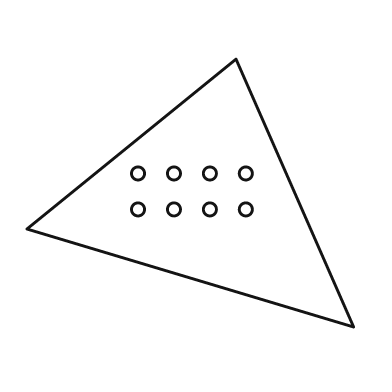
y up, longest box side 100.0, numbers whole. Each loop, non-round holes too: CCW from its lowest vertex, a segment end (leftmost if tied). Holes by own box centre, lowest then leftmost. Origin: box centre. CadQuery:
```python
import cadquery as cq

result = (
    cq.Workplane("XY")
    .moveTo(50.0, -41.0)
    .lineTo(14.0, 41.0)
    .lineTo(-50.0, -11.0)
    .close()
    .moveTo(-16.0, -5.0)
    .circle(2.0)
    .moveTo(-5.0, -5.0)
    .circle(2.0)
    .moveTo(6.0, -5.0)
    .circle(2.0)
    .moveTo(17.0, -5.0)
    .circle(2.0)
    .moveTo(-16.0, 6.0)
    .circle(2.0)
    .moveTo(-5.0, 6.0)
    .circle(2.0)
    .moveTo(6.0, 6.0)
    .circle(2.0)
    .moveTo(17.0, 6.0)
    .circle(2.0)
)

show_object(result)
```